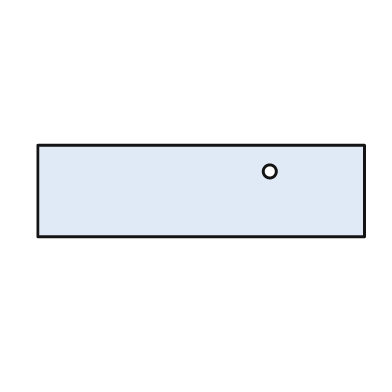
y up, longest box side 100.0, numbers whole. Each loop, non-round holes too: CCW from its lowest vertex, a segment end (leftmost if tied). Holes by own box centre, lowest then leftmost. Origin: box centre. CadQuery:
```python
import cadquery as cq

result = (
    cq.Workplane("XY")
    .moveTo(-50.0, -14.0)
    .lineTo(50.0, -14.0)
    .lineTo(50.0, 14.0)
    .lineTo(-50.0, 14.0)
    .close()
    .moveTo(21.0, 6.0)
    .circle(2.0)
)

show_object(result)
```